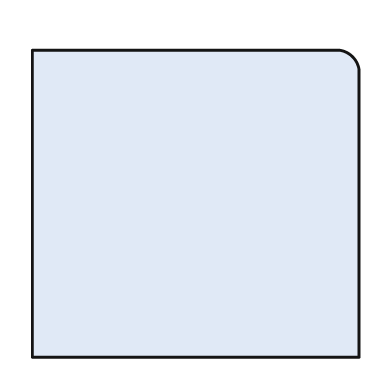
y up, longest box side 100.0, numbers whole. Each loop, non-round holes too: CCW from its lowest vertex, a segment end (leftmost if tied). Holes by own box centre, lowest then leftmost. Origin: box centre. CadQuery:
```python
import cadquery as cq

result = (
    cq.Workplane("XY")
    .moveTo(-50.0, -47.0)
    .lineTo(50.0, -47.0)
    .lineTo(50.0, 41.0)
    .threePointArc((48.0, 45.0), (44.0, 47.0))
    .lineTo(-50.0, 47.0)
    .close()
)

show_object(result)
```